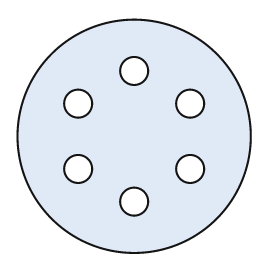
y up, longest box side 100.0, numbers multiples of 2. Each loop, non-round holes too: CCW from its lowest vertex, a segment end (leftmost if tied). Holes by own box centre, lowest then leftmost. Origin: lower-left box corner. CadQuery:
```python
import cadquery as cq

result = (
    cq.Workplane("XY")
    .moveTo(50.0, 50.0)
    .circle(50.0)
    .moveTo(50.0, 22.0)
    .circle(6.0)
    .moveTo(26.0, 36.0)
    .circle(6.0)
    .moveTo(74.0, 36.0)
    .circle(6.0)
    .moveTo(26.0, 64.0)
    .circle(6.0)
    .moveTo(74.0, 64.0)
    .circle(6.0)
    .moveTo(50.0, 78.0)
    .circle(6.0)
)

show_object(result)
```